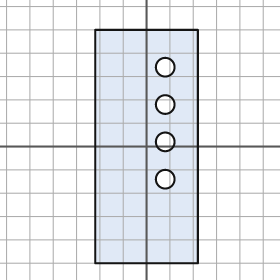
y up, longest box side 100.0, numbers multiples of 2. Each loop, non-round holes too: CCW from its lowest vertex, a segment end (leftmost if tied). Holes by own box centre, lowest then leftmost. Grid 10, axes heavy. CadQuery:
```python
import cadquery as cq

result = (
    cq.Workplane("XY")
    .moveTo(-22.0, -50.0)
    .lineTo(22.0, -50.0)
    .lineTo(22.0, 50.0)
    .lineTo(-22.0, 50.0)
    .close()
    .moveTo(8.0, -14.0)
    .circle(4.0)
    .moveTo(8.0, 2.0)
    .circle(4.0)
    .moveTo(8.0, 18.0)
    .circle(4.0)
    .moveTo(8.0, 34.0)
    .circle(4.0)
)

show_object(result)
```